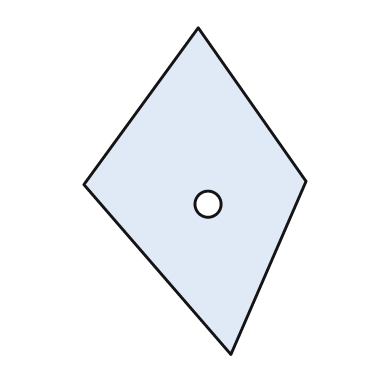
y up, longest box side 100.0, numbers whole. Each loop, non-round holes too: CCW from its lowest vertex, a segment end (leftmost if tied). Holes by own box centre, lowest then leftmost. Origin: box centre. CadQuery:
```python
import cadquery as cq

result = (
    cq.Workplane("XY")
    .moveTo(11.0, -50.0)
    .lineTo(34.0, 3.0)
    .lineTo(1.0, 50.0)
    .lineTo(-34.0, 2.0)
    .close()
    .moveTo(4.0, -4.0)
    .circle(4.0)
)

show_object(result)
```